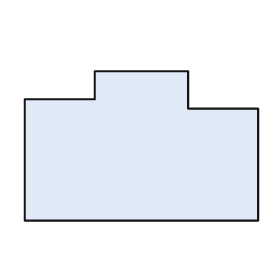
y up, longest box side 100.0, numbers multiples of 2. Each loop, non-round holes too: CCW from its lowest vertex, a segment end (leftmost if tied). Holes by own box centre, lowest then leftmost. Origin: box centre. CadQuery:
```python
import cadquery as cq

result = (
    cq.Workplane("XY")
    .moveTo(-50.0, -32.0)
    .lineTo(50.0, -32.0)
    .lineTo(50.0, 16.0)
    .lineTo(20.0, 16.0)
    .lineTo(20.0, 32.0)
    .lineTo(-20.0, 32.0)
    .lineTo(-20.0, 20.0)
    .lineTo(-50.0, 20.0)
    .close()
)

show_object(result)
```